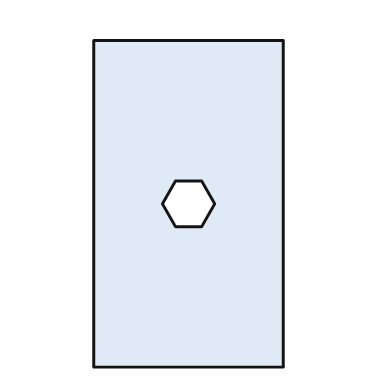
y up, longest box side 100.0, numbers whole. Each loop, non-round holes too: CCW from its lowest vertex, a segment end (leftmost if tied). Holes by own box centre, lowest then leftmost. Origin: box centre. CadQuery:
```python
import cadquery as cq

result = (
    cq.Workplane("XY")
    .moveTo(-29.0, -50.0)
    .lineTo(29.0, -50.0)
    .lineTo(29.0, 50.0)
    .lineTo(-29.0, 50.0)
    .close()
    .moveTo(-4.0, -7.0)
    .lineTo(4.0, -7.0)
    .lineTo(8.0, 0.0)
    .lineTo(4.0, 7.0)
    .lineTo(-4.0, 7.0)
    .lineTo(-8.0, 0.0)
    .close()
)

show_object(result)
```